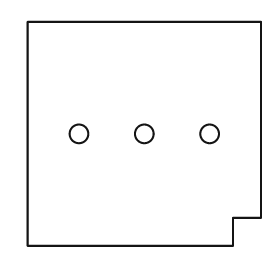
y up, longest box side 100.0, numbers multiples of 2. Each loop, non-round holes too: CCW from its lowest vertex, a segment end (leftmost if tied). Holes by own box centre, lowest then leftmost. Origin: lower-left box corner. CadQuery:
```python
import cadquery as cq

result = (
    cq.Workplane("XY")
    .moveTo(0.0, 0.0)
    .lineTo(88.0, 0.0)
    .lineTo(88.0, 12.0)
    .lineTo(100.0, 12.0)
    .lineTo(100.0, 96.0)
    .lineTo(0.0, 96.0)
    .close()
    .moveTo(22.0, 48.0)
    .circle(4.0)
    .moveTo(50.0, 48.0)
    .circle(4.0)
    .moveTo(78.0, 48.0)
    .circle(4.0)
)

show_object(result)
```